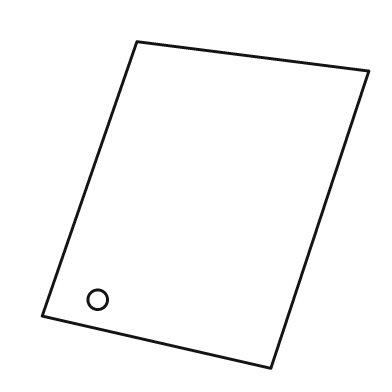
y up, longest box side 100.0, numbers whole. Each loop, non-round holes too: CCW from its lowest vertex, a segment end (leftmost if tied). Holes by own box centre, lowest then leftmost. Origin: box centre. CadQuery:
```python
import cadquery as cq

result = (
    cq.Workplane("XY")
    .moveTo(20.0, -50.0)
    .lineTo(50.0, 41.0)
    .lineTo(-21.0, 50.0)
    .lineTo(-50.0, -34.0)
    .close()
    .moveTo(-33.0, -29.0)
    .circle(3.0)
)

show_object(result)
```